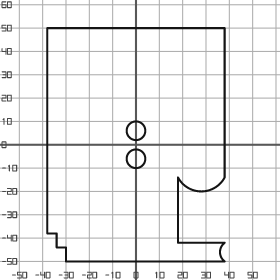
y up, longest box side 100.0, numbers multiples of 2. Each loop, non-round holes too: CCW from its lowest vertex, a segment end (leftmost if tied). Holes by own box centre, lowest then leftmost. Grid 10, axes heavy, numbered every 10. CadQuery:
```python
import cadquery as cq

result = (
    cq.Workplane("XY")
    .moveTo(-30.0, -50.0)
    .lineTo(38.0, -50.0)
    .threePointArc((36.0, -46.0), (38.0, -42.0))
    .lineTo(18.0, -42.0)
    .lineTo(18.0, -14.0)
    .threePointArc((28.0, -20.0), (38.0, -14.0))
    .lineTo(38.0, 50.0)
    .lineTo(-38.0, 50.0)
    .lineTo(-38.0, -38.0)
    .lineTo(-34.0, -38.0)
    .lineTo(-34.0, -44.0)
    .lineTo(-30.0, -44.0)
    .close()
    .moveTo(0.0, -6.0)
    .circle(4.0)
    .moveTo(0.0, 6.0)
    .circle(4.0)
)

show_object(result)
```